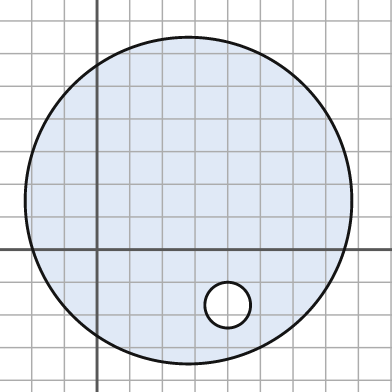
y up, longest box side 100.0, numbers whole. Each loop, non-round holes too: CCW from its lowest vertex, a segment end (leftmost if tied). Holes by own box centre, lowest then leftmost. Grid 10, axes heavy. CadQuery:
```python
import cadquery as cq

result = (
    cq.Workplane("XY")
    .moveTo(28.0, 15.0)
    .circle(50.0)
    .moveTo(40.0, -17.0)
    .circle(7.0)
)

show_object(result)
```